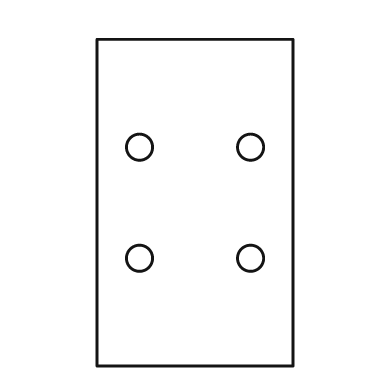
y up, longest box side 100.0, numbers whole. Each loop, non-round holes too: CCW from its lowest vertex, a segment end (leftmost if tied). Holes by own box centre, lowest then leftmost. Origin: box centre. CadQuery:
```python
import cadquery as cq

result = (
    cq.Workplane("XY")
    .moveTo(-30.0, -50.0)
    .lineTo(30.0, -50.0)
    .lineTo(30.0, 50.0)
    .lineTo(-30.0, 50.0)
    .close()
    .moveTo(-17.0, -17.0)
    .circle(4.0)
    .moveTo(17.0, -17.0)
    .circle(4.0)
    .moveTo(-17.0, 17.0)
    .circle(4.0)
    .moveTo(17.0, 17.0)
    .circle(4.0)
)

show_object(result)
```